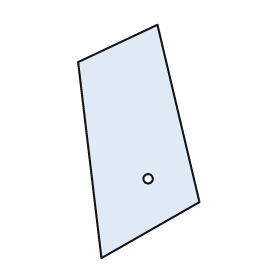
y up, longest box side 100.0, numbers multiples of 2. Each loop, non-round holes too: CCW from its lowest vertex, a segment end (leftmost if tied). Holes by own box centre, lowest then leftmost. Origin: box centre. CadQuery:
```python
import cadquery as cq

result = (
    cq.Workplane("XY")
    .moveTo(-16.0, -50.0)
    .lineTo(26.0, -26.0)
    .lineTo(8.0, 50.0)
    .lineTo(-26.0, 34.0)
    .close()
    .moveTo(4.0, -16.0)
    .circle(2.0)
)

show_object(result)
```